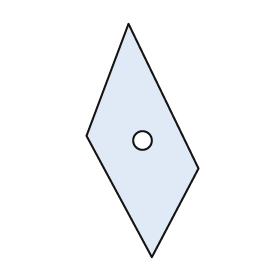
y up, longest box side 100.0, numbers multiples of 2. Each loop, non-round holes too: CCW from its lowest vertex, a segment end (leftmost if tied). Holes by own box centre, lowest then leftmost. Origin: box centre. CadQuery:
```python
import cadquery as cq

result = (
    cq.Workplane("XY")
    .moveTo(4.0, -50.0)
    .lineTo(24.0, -12.0)
    .lineTo(-6.0, 50.0)
    .lineTo(-24.0, 2.0)
    .close()
    .moveTo(0.0, 0.0)
    .circle(4.0)
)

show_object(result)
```